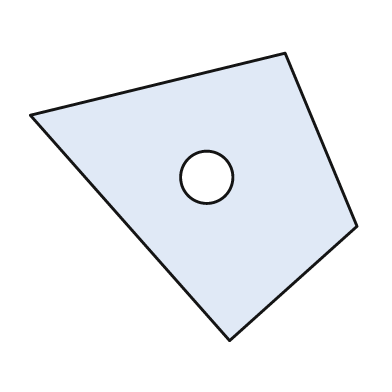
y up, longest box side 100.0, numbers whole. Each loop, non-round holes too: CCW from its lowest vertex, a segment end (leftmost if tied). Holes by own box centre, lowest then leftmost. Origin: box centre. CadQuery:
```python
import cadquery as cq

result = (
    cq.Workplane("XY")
    .moveTo(11.0, -44.0)
    .lineTo(50.0, -9.0)
    .lineTo(28.0, 44.0)
    .lineTo(-50.0, 25.0)
    .close()
    .moveTo(4.0, 6.0)
    .circle(8.0)
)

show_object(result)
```